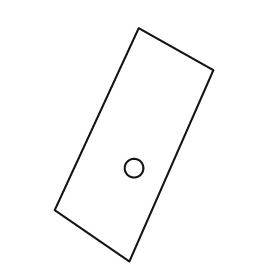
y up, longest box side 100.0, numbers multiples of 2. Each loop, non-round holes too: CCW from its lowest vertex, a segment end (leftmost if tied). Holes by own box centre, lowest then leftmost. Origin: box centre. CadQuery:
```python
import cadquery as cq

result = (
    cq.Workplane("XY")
    .moveTo(-2.0, -50.0)
    .lineTo(34.0, 32.0)
    .lineTo(2.0, 50.0)
    .lineTo(-34.0, -28.0)
    .close()
    .moveTo(0.0, -10.0)
    .circle(4.0)
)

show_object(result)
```